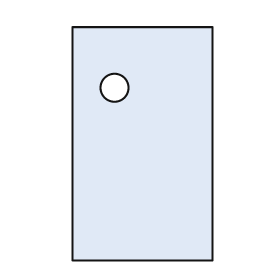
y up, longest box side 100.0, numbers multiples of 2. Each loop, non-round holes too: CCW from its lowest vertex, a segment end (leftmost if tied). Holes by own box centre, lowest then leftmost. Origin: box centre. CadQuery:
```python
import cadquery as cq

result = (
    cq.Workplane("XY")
    .moveTo(-30.0, -50.0)
    .lineTo(30.0, -50.0)
    .lineTo(30.0, 50.0)
    .lineTo(-30.0, 50.0)
    .close()
    .moveTo(-12.0, 24.0)
    .circle(6.0)
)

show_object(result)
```